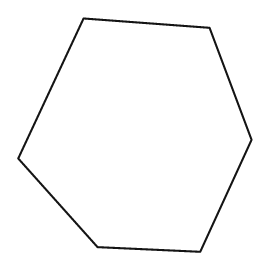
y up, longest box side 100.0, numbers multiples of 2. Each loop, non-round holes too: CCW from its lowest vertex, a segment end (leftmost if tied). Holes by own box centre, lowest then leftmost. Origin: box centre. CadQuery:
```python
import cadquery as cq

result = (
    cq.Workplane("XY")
    .moveTo(28.0, -50.0)
    .lineTo(50.0, -2.0)
    .lineTo(32.0, 46.0)
    .lineTo(-22.0, 50.0)
    .lineTo(-50.0, -10.0)
    .lineTo(-16.0, -48.0)
    .close()
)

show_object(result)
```